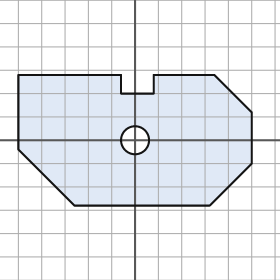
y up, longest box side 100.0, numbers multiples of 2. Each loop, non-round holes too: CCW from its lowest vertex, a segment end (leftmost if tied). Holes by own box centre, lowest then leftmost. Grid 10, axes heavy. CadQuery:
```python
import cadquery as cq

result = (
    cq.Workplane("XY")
    .moveTo(-26.0, -28.0)
    .lineTo(32.0, -28.0)
    .lineTo(50.0, -10.0)
    .lineTo(50.0, 12.0)
    .lineTo(34.0, 28.0)
    .lineTo(8.0, 28.0)
    .lineTo(8.0, 20.0)
    .lineTo(-6.0, 20.0)
    .lineTo(-6.0, 28.0)
    .lineTo(-50.0, 28.0)
    .lineTo(-50.0, -4.0)
    .close()
    .moveTo(0.0, 0.0)
    .circle(6.0)
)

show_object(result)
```